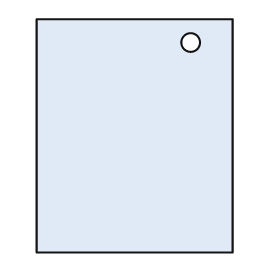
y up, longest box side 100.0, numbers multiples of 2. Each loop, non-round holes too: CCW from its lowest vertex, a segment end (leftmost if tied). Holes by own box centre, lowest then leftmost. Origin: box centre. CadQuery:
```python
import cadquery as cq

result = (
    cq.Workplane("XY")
    .moveTo(-42.0, -50.0)
    .lineTo(42.0, -50.0)
    .lineTo(42.0, 50.0)
    .lineTo(-42.0, 50.0)
    .close()
    .moveTo(24.0, 40.0)
    .circle(4.0)
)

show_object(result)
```